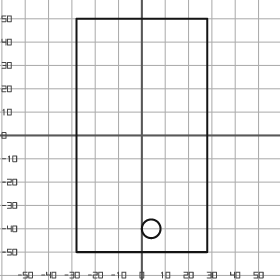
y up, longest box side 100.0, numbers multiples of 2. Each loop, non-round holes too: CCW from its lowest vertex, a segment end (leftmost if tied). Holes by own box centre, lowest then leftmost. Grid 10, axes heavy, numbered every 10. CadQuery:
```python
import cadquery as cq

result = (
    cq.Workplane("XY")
    .moveTo(-28.0, -50.0)
    .lineTo(28.0, -50.0)
    .lineTo(28.0, 50.0)
    .lineTo(-28.0, 50.0)
    .close()
    .moveTo(4.0, -40.0)
    .circle(4.0)
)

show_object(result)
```